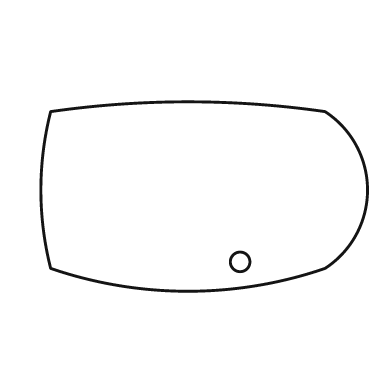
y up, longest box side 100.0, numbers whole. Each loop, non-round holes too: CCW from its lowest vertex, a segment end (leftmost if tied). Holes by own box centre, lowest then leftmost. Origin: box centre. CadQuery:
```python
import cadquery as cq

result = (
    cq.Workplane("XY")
    .moveTo(-47.0, -22.0)
    .threePointArc((-5.0, -29.0), (37.0, -22.0))
    .threePointArc((50.0, 2.0), (37.0, 26.0))
    .threePointArc((-5.0, 29.0), (-47.0, 26.0))
    .threePointArc((-50.0, 2.0), (-47.0, -22.0))
    .close()
    .moveTo(11.0, -20.0)
    .circle(3.0)
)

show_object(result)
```